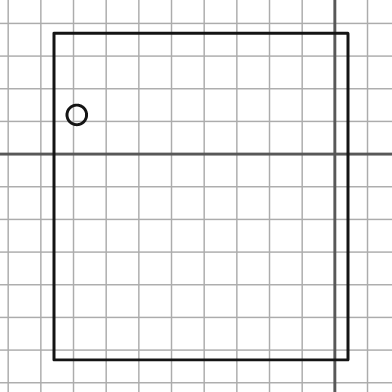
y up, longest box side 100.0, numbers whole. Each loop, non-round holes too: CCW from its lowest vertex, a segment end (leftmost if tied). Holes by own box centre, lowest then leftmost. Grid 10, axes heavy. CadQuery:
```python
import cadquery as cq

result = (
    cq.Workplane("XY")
    .moveTo(-86.0, -63.0)
    .lineTo(4.0, -63.0)
    .lineTo(4.0, 37.0)
    .lineTo(-86.0, 37.0)
    .close()
    .moveTo(-79.0, 12.0)
    .circle(3.0)
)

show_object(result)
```